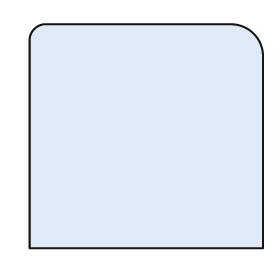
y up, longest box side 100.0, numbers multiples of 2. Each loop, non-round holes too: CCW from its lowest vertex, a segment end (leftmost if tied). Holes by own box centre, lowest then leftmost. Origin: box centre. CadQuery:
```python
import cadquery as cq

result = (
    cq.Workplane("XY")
    .moveTo(-50.0, -48.0)
    .lineTo(50.0, -48.0)
    .lineTo(50.0, 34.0)
    .threePointArc((46.0, 44.0), (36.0, 48.0))
    .lineTo(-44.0, 48.0)
    .threePointArc((-48.0, 46.0), (-50.0, 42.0))
    .close()
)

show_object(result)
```